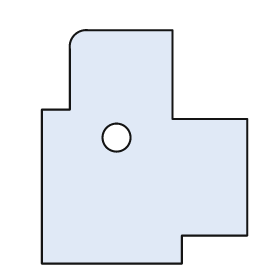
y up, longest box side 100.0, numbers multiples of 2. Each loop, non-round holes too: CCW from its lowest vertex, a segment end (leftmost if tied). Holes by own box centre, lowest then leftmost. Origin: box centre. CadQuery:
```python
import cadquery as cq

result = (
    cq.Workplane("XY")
    .moveTo(-44.0, -50.0)
    .lineTo(16.0, -50.0)
    .lineTo(16.0, -38.0)
    .lineTo(44.0, -38.0)
    .lineTo(44.0, 12.0)
    .lineTo(12.0, 12.0)
    .lineTo(12.0, 50.0)
    .lineTo(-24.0, 50.0)
    .threePointArc((-30.0, 48.0), (-32.0, 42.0))
    .lineTo(-32.0, 16.0)
    .lineTo(-44.0, 16.0)
    .close()
    .moveTo(-12.0, 4.0)
    .circle(6.0)
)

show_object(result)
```